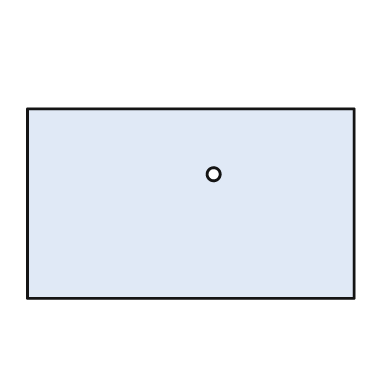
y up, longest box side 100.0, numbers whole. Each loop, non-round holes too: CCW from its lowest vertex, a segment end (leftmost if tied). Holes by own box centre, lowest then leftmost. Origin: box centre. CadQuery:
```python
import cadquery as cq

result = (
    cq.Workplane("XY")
    .moveTo(-50.0, -29.0)
    .lineTo(50.0, -29.0)
    .lineTo(50.0, 29.0)
    .lineTo(-50.0, 29.0)
    .close()
    .moveTo(7.0, 9.0)
    .circle(2.0)
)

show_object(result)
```